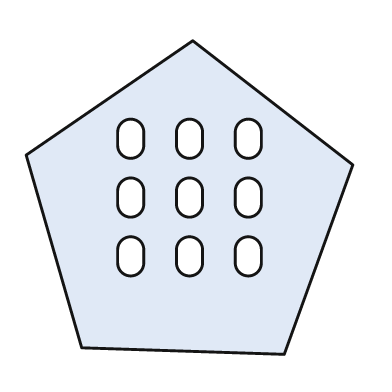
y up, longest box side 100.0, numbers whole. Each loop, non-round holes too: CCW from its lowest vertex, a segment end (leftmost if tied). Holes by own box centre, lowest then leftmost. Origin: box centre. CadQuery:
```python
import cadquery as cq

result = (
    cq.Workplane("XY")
    .moveTo(29.0, -48.0)
    .lineTo(50.0, 10.0)
    .lineTo(1.0, 48.0)
    .lineTo(-50.0, 13.0)
    .lineTo(-33.0, -46.0)
    .close()
    .moveTo(-22.0, -20.0)
    .threePointArc((-18.0, -24.0), (-14.0, -20.0))
    .lineTo(-14.0, -16.0)
    .threePointArc((-18.0, -12.0), (-22.0, -16.0))
    .close()
    .moveTo(-4.0, -20.0)
    .threePointArc((0.0, -24.0), (4.0, -20.0))
    .lineTo(4.0, -16.0)
    .threePointArc((0.0, -12.0), (-4.0, -16.0))
    .close()
    .moveTo(14.0, -20.0)
    .threePointArc((18.0, -24.0), (22.0, -20.0))
    .lineTo(22.0, -16.0)
    .threePointArc((18.0, -12.0), (14.0, -16.0))
    .close()
    .moveTo(-22.0, -2.0)
    .threePointArc((-18.0, -6.0), (-14.0, -2.0))
    .lineTo(-14.0, 2.0)
    .threePointArc((-18.0, 6.0), (-22.0, 2.0))
    .close()
    .moveTo(-4.0, -2.0)
    .threePointArc((0.0, -6.0), (4.0, -2.0))
    .lineTo(4.0, 2.0)
    .threePointArc((0.0, 6.0), (-4.0, 2.0))
    .close()
    .moveTo(14.0, -2.0)
    .threePointArc((18.0, -6.0), (22.0, -2.0))
    .lineTo(22.0, 2.0)
    .threePointArc((18.0, 6.0), (14.0, 2.0))
    .close()
    .moveTo(-22.0, 16.0)
    .threePointArc((-18.0, 12.0), (-14.0, 16.0))
    .lineTo(-14.0, 20.0)
    .threePointArc((-18.0, 24.0), (-22.0, 20.0))
    .close()
    .moveTo(-4.0, 16.0)
    .threePointArc((0.0, 12.0), (4.0, 16.0))
    .lineTo(4.0, 20.0)
    .threePointArc((0.0, 24.0), (-4.0, 20.0))
    .close()
    .moveTo(14.0, 16.0)
    .threePointArc((18.0, 12.0), (22.0, 16.0))
    .lineTo(22.0, 20.0)
    .threePointArc((18.0, 24.0), (14.0, 20.0))
    .close()
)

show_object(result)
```